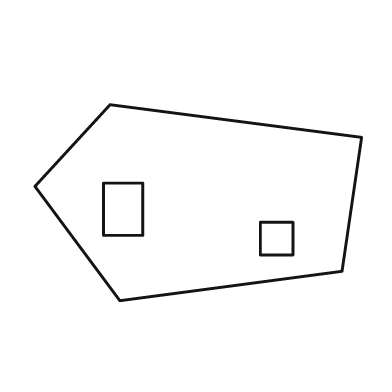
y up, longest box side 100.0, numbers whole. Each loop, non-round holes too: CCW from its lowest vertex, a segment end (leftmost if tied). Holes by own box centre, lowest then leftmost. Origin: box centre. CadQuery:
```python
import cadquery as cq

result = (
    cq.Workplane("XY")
    .moveTo(-24.0, -30.0)
    .lineTo(44.0, -21.0)
    .lineTo(50.0, 20.0)
    .lineTo(-27.0, 30.0)
    .lineTo(-50.0, 5.0)
    .close()
    .moveTo(19.0, -16.0)
    .lineTo(29.0, -16.0)
    .lineTo(29.0, -6.0)
    .lineTo(19.0, -6.0)
    .close()
    .moveTo(-29.0, -10.0)
    .lineTo(-17.0, -10.0)
    .lineTo(-17.0, 6.0)
    .lineTo(-29.0, 6.0)
    .close()
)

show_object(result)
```